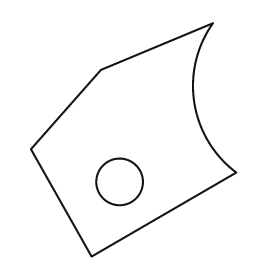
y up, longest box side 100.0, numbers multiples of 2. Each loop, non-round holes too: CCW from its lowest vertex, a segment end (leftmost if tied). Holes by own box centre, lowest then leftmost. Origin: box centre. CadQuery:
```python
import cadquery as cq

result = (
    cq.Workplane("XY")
    .moveTo(-18.0, -50.0)
    .lineTo(44.0, -14.0)
    .threePointArc((26.0, 16.0), (34.0, 50.0))
    .lineTo(-14.0, 30.0)
    .lineTo(-44.0, -4.0)
    .close()
    .moveTo(-6.0, -18.0)
    .circle(10.0)
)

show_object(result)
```